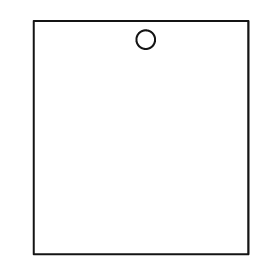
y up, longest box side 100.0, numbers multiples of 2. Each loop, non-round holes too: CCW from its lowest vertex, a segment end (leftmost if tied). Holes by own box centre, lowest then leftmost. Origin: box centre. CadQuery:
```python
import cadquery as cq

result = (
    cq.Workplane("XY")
    .moveTo(-46.0, -50.0)
    .lineTo(46.0, -50.0)
    .lineTo(46.0, 50.0)
    .lineTo(-46.0, 50.0)
    .close()
    .moveTo(2.0, 42.0)
    .circle(4.0)
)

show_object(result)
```